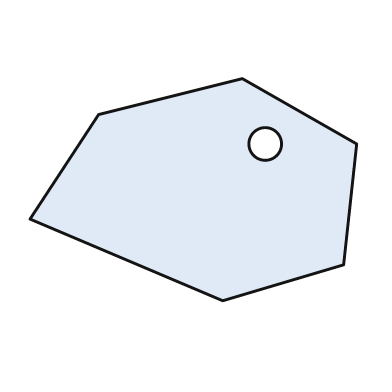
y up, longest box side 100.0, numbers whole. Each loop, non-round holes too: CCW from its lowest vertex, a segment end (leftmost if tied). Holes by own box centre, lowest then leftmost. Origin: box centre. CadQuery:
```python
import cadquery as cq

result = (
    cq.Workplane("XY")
    .moveTo(9.0, -34.0)
    .lineTo(46.0, -23.0)
    .lineTo(50.0, 14.0)
    .lineTo(15.0, 34.0)
    .lineTo(-29.0, 23.0)
    .lineTo(-50.0, -9.0)
    .close()
    .moveTo(22.0, 14.0)
    .circle(5.0)
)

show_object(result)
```